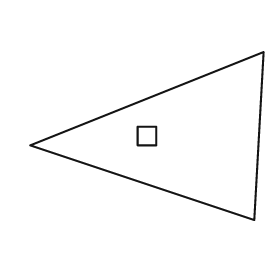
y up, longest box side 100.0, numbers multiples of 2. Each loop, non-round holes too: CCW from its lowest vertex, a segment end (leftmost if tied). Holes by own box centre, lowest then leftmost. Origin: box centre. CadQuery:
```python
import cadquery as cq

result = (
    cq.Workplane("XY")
    .moveTo(46.0, -36.0)
    .lineTo(50.0, 36.0)
    .lineTo(-50.0, -4.0)
    .close()
    .moveTo(-4.0, -4.0)
    .lineTo(4.0, -4.0)
    .lineTo(4.0, 4.0)
    .lineTo(-4.0, 4.0)
    .close()
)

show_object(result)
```